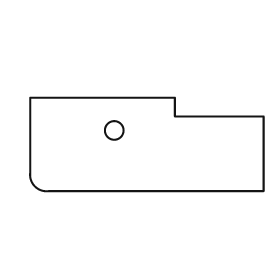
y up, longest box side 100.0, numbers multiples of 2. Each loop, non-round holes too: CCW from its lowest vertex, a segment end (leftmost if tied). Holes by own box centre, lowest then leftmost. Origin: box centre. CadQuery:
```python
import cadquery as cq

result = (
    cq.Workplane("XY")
    .moveTo(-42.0, -20.0)
    .lineTo(50.0, -20.0)
    .lineTo(50.0, 12.0)
    .lineTo(12.0, 12.0)
    .lineTo(12.0, 20.0)
    .lineTo(-50.0, 20.0)
    .lineTo(-50.0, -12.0)
    .threePointArc((-48.0, -18.0), (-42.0, -20.0))
    .close()
    .moveTo(-14.0, 6.0)
    .circle(4.0)
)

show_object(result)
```